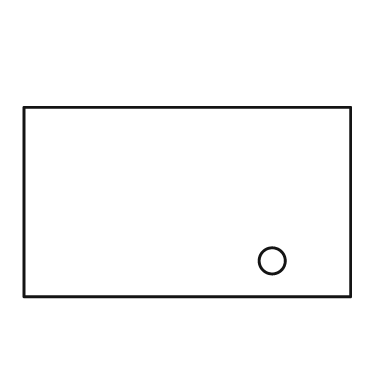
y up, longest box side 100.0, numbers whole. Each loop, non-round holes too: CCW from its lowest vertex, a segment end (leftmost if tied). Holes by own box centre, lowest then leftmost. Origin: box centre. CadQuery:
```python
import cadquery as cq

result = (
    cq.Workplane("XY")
    .moveTo(-50.0, -29.0)
    .lineTo(50.0, -29.0)
    .lineTo(50.0, 29.0)
    .lineTo(-50.0, 29.0)
    .close()
    .moveTo(26.0, -18.0)
    .circle(4.0)
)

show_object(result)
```